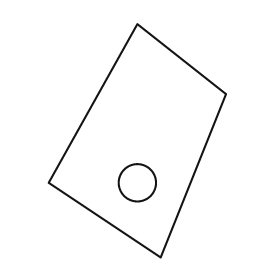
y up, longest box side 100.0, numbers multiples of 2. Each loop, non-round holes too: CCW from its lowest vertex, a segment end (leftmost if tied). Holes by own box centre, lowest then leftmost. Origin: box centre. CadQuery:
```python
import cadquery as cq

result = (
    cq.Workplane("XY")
    .moveTo(10.0, -50.0)
    .lineTo(38.0, 20.0)
    .lineTo(0.0, 50.0)
    .lineTo(-38.0, -18.0)
    .close()
    .moveTo(0.0, -18.0)
    .circle(8.0)
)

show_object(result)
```